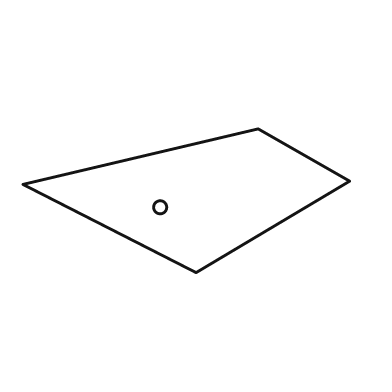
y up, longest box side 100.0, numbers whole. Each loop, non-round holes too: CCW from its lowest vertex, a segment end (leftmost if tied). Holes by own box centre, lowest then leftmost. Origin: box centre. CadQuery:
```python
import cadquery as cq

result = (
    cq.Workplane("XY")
    .moveTo(3.0, -22.0)
    .lineTo(50.0, 6.0)
    .lineTo(22.0, 22.0)
    .lineTo(-50.0, 5.0)
    .close()
    .moveTo(-8.0, -2.0)
    .circle(2.0)
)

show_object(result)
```